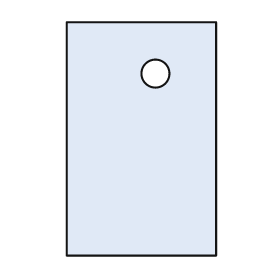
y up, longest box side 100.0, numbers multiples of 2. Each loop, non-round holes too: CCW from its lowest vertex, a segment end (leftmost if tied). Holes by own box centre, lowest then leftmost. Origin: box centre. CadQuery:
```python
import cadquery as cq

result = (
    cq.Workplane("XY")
    .moveTo(-32.0, -50.0)
    .lineTo(32.0, -50.0)
    .lineTo(32.0, 50.0)
    .lineTo(-32.0, 50.0)
    .close()
    .moveTo(6.0, 28.0)
    .circle(6.0)
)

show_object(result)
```